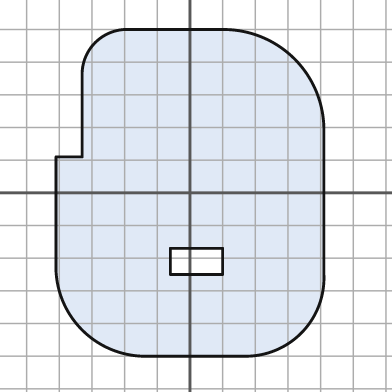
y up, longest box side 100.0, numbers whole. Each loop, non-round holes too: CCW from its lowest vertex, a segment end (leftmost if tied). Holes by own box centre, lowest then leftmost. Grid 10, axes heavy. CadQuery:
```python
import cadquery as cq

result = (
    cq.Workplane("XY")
    .moveTo(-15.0, -50.0)
    .lineTo(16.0, -50.0)
    .threePointArc((34.0, -43.0), (41.0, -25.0))
    .lineTo(41.0, 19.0)
    .threePointArc((32.0, 41.0), (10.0, 50.0))
    .lineTo(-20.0, 50.0)
    .threePointArc((-29.0, 46.0), (-33.0, 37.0))
    .lineTo(-33.0, 11.0)
    .lineTo(-41.0, 11.0)
    .lineTo(-41.0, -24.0)
    .threePointArc((-33.0, -42.0), (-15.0, -50.0))
    .close()
    .moveTo(-6.0, -25.0)
    .lineTo(10.0, -25.0)
    .lineTo(10.0, -17.0)
    .lineTo(-6.0, -17.0)
    .close()
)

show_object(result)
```